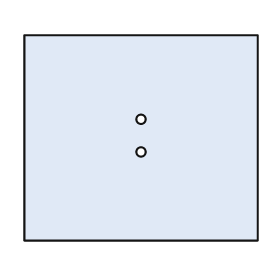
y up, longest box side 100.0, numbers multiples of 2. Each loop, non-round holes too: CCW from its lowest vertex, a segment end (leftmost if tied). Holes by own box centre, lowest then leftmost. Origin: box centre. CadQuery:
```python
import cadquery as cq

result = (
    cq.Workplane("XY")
    .moveTo(-50.0, -44.0)
    .lineTo(50.0, -44.0)
    .lineTo(50.0, 44.0)
    .lineTo(-50.0, 44.0)
    .close()
    .moveTo(0.0, -6.0)
    .circle(2.0)
    .moveTo(0.0, 8.0)
    .circle(2.0)
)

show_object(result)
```